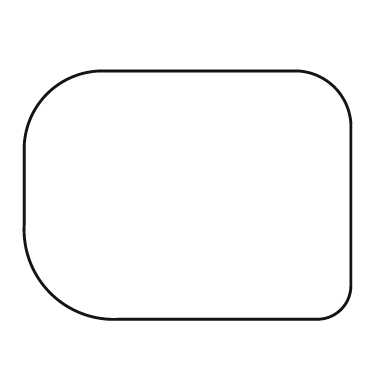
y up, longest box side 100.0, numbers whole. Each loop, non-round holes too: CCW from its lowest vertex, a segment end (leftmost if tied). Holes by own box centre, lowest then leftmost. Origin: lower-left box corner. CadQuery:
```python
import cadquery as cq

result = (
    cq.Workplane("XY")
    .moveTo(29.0, 0.0)
    .lineTo(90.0, 0.0)
    .threePointArc((97.0, 3.0), (100.0, 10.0))
    .lineTo(100.0, 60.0)
    .threePointArc((95.0, 71.0), (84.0, 76.0))
    .lineTo(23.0, 76.0)
    .threePointArc((7.0, 69.0), (0.0, 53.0))
    .lineTo(0.0, 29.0)
    .threePointArc((8.0, 8.0), (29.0, 0.0))
    .close()
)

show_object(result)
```